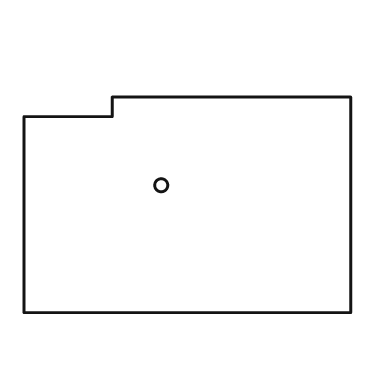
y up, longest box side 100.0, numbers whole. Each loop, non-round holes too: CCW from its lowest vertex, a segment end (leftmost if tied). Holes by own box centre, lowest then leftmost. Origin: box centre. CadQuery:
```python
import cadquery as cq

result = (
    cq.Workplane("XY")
    .moveTo(-50.0, -33.0)
    .lineTo(50.0, -33.0)
    .lineTo(50.0, 33.0)
    .lineTo(-23.0, 33.0)
    .lineTo(-23.0, 27.0)
    .lineTo(-50.0, 27.0)
    .close()
    .moveTo(-8.0, 6.0)
    .circle(2.0)
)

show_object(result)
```